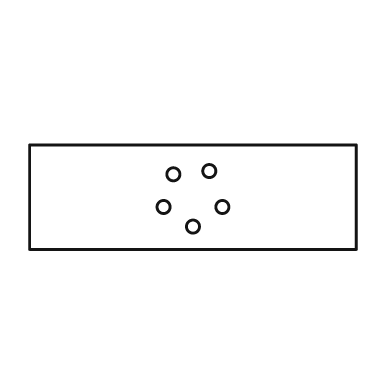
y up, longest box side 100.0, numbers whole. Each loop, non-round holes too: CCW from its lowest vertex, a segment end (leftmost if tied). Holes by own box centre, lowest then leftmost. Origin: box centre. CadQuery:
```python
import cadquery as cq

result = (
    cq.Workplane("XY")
    .moveTo(-50.0, -16.0)
    .lineTo(50.0, -16.0)
    .lineTo(50.0, 16.0)
    .lineTo(-50.0, 16.0)
    .close()
    .moveTo(0.0, -9.0)
    .circle(2.0)
    .moveTo(-9.0, -3.0)
    .circle(2.0)
    .moveTo(9.0, -3.0)
    .circle(2.0)
    .moveTo(-6.0, 7.0)
    .circle(2.0)
    .moveTo(5.0, 8.0)
    .circle(2.0)
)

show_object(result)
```